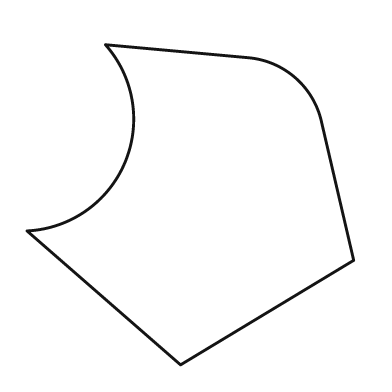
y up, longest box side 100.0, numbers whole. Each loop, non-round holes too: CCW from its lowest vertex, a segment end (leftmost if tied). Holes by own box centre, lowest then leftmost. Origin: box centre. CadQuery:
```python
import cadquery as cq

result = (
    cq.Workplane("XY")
    .moveTo(-3.0, -49.0)
    .lineTo(50.0, -17.0)
    .lineTo(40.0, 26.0)
    .threePointArc((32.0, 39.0), (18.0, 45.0))
    .lineTo(-26.0, 49.0)
    .threePointArc((-20.0, 13.0), (-50.0, -8.0))
    .close()
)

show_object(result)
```